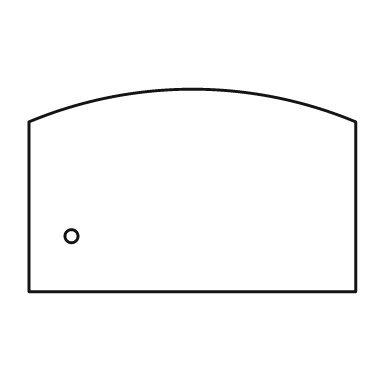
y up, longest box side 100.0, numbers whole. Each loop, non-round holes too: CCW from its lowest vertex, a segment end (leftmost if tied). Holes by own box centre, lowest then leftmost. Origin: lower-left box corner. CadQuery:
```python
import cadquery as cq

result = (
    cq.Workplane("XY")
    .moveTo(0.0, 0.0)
    .lineTo(100.0, 0.0)
    .lineTo(100.0, 52.0)
    .threePointArc((50.0, 62.0), (0.0, 52.0))
    .close()
    .moveTo(13.0, 17.0)
    .circle(2.0)
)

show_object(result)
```